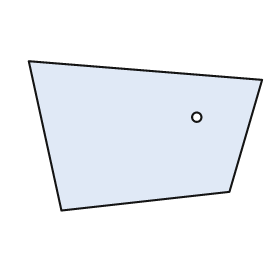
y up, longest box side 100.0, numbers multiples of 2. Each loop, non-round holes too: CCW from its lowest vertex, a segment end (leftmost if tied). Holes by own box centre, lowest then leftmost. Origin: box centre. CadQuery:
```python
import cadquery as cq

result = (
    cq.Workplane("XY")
    .moveTo(-36.0, -32.0)
    .lineTo(36.0, -24.0)
    .lineTo(50.0, 24.0)
    .lineTo(-50.0, 32.0)
    .close()
    .moveTo(22.0, 8.0)
    .circle(2.0)
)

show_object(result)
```